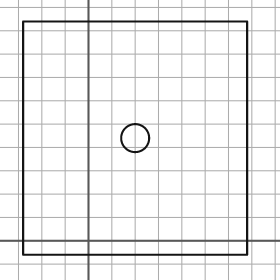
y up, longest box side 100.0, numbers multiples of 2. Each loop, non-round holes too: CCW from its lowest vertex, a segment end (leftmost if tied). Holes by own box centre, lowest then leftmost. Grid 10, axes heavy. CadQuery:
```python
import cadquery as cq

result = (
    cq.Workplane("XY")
    .moveTo(-28.0, -6.0)
    .lineTo(68.0, -6.0)
    .lineTo(68.0, 94.0)
    .lineTo(-28.0, 94.0)
    .close()
    .moveTo(20.0, 44.0)
    .circle(6.0)
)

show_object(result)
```